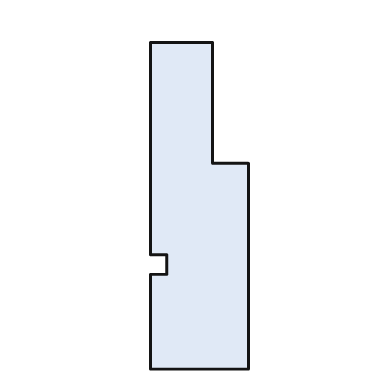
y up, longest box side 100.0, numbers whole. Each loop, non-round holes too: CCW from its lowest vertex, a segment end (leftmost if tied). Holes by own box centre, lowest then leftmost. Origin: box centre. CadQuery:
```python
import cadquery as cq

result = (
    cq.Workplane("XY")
    .moveTo(-15.0, -50.0)
    .lineTo(15.0, -50.0)
    .lineTo(15.0, 13.0)
    .lineTo(4.0, 13.0)
    .lineTo(4.0, 50.0)
    .lineTo(-15.0, 50.0)
    .lineTo(-15.0, -15.0)
    .lineTo(-10.0, -15.0)
    .lineTo(-10.0, -21.0)
    .lineTo(-15.0, -21.0)
    .close()
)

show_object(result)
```